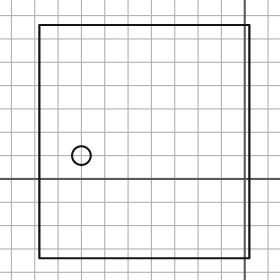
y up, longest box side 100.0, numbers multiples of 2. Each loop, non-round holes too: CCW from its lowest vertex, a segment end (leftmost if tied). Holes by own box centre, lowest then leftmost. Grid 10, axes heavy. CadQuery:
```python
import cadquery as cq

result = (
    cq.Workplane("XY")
    .moveTo(-88.0, -34.0)
    .lineTo(2.0, -34.0)
    .lineTo(2.0, 66.0)
    .lineTo(-88.0, 66.0)
    .close()
    .moveTo(-70.0, 10.0)
    .circle(4.0)
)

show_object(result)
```